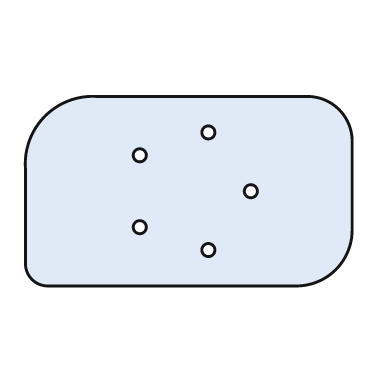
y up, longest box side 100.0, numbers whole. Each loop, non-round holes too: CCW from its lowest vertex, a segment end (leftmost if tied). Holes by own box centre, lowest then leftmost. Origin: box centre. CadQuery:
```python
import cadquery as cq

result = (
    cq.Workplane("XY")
    .moveTo(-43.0, -29.0)
    .lineTo(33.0, -29.0)
    .threePointArc((45.0, -24.0), (50.0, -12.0))
    .lineTo(50.0, 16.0)
    .threePointArc((46.0, 25.0), (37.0, 29.0))
    .lineTo(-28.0, 29.0)
    .threePointArc((-44.0, 23.0), (-50.0, 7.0))
    .lineTo(-50.0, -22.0)
    .threePointArc((-48.0, -27.0), (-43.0, -29.0))
    .close()
    .moveTo(6.0, -18.0)
    .circle(2.0)
    .moveTo(-15.0, -11.0)
    .circle(2.0)
    .moveTo(19.0, 0.0)
    .circle(2.0)
    .moveTo(-15.0, 11.0)
    .circle(2.0)
    .moveTo(6.0, 18.0)
    .circle(2.0)
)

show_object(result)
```